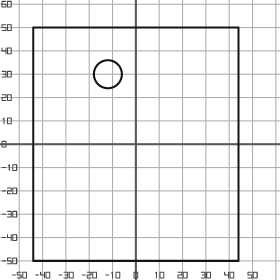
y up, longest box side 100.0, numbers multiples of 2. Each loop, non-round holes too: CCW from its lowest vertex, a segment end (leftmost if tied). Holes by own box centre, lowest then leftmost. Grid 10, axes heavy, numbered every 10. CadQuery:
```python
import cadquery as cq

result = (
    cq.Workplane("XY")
    .moveTo(-44.0, -50.0)
    .lineTo(44.0, -50.0)
    .lineTo(44.0, 50.0)
    .lineTo(-44.0, 50.0)
    .close()
    .moveTo(-12.0, 30.0)
    .circle(6.0)
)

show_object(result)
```